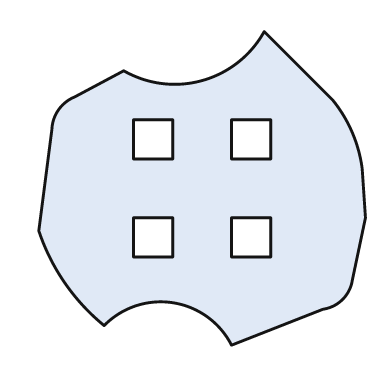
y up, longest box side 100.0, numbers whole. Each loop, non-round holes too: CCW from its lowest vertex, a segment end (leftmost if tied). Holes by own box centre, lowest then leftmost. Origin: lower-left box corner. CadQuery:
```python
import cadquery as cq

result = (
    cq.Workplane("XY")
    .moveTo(59.0, 0.0)
    .lineTo(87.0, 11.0)
    .threePointArc((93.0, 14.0), (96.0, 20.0))
    .lineTo(100.0, 39.0)
    .lineTo(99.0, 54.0)
    .threePointArc((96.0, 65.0), (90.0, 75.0))
    .lineTo(69.0, 96.0)
    .threePointArc((50.0, 81.0), (26.0, 84.0))
    .lineTo(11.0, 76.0)
    .threePointArc((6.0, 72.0), (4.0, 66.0))
    .lineTo(0.0, 35.0)
    .threePointArc((8.0, 19.0), (20.0, 6.0))
    .threePointArc((41.0, 13.0), (59.0, 0.0))
    .close()
    .moveTo(29.0, 27.0)
    .lineTo(41.0, 27.0)
    .lineTo(41.0, 39.0)
    .lineTo(29.0, 39.0)
    .close()
    .moveTo(59.0, 27.0)
    .lineTo(71.0, 27.0)
    .lineTo(71.0, 39.0)
    .lineTo(59.0, 39.0)
    .close()
    .moveTo(29.0, 57.0)
    .lineTo(41.0, 57.0)
    .lineTo(41.0, 69.0)
    .lineTo(29.0, 69.0)
    .close()
    .moveTo(59.0, 57.0)
    .lineTo(71.0, 57.0)
    .lineTo(71.0, 69.0)
    .lineTo(59.0, 69.0)
    .close()
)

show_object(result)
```